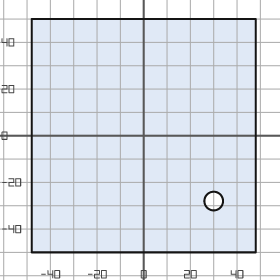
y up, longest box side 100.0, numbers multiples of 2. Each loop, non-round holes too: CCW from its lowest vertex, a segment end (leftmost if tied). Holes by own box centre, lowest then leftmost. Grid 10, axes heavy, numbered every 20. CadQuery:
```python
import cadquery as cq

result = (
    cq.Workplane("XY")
    .moveTo(-48.0, -50.0)
    .lineTo(48.0, -50.0)
    .lineTo(48.0, 50.0)
    .lineTo(-48.0, 50.0)
    .close()
    .moveTo(30.0, -28.0)
    .circle(4.0)
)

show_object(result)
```